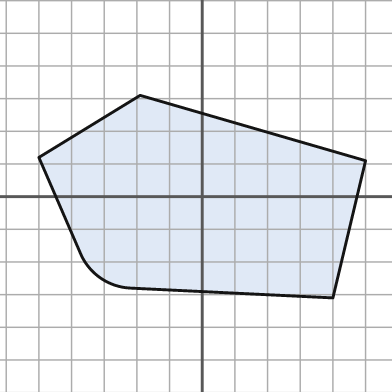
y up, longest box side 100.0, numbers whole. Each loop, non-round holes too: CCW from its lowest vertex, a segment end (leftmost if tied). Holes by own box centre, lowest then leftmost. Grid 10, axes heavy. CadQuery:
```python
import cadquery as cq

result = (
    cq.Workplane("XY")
    .moveTo(40.0, -31.0)
    .lineTo(50.0, 11.0)
    .lineTo(-19.0, 31.0)
    .lineTo(-50.0, 12.0)
    .lineTo(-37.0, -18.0)
    .threePointArc((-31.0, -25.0), (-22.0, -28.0))
    .close()
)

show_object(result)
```